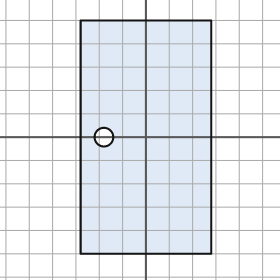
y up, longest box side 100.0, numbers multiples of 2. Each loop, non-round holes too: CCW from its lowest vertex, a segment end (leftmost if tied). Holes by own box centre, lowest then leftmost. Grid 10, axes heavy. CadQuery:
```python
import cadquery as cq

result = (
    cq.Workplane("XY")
    .moveTo(-28.0, -50.0)
    .lineTo(28.0, -50.0)
    .lineTo(28.0, 50.0)
    .lineTo(-28.0, 50.0)
    .close()
    .moveTo(-18.0, 0.0)
    .circle(4.0)
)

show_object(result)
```